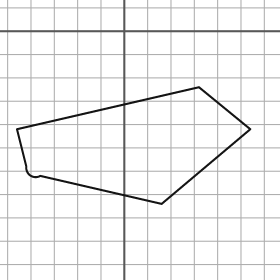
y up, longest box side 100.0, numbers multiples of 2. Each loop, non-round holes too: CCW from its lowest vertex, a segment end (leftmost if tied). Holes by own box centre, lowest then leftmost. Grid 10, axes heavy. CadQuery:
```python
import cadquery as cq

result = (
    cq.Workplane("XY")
    .moveTo(16.0, -74.0)
    .lineTo(54.0, -42.0)
    .lineTo(32.0, -24.0)
    .lineTo(-46.0, -42.0)
    .lineTo(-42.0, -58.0)
    .threePointArc((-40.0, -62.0), (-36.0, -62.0))
    .close()
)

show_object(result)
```